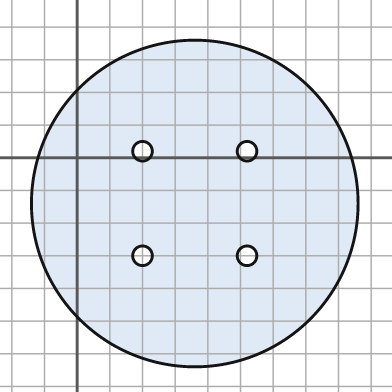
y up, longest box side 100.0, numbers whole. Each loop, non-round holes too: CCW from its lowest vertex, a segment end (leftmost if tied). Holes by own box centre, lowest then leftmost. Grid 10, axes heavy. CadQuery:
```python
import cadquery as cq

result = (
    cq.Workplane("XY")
    .moveTo(36.0, -14.0)
    .circle(50.0)
    .moveTo(20.0, -30.0)
    .circle(3.0)
    .moveTo(52.0, -30.0)
    .circle(3.0)
    .moveTo(20.0, 2.0)
    .circle(3.0)
    .moveTo(52.0, 2.0)
    .circle(3.0)
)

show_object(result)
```